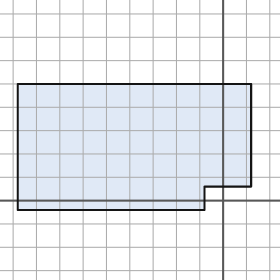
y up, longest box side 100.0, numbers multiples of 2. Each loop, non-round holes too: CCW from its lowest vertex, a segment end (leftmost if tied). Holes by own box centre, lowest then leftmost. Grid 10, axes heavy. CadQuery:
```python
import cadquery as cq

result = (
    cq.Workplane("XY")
    .moveTo(-88.0, -4.0)
    .lineTo(-8.0, -4.0)
    .lineTo(-8.0, 6.0)
    .lineTo(12.0, 6.0)
    .lineTo(12.0, 50.0)
    .lineTo(-88.0, 50.0)
    .close()
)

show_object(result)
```